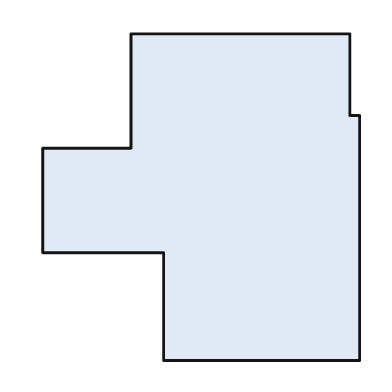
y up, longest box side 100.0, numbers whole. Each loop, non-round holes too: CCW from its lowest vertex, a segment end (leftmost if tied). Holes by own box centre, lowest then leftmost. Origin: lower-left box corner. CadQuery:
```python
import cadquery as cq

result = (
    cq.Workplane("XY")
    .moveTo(37.0, 0.0)
    .lineTo(97.0, 0.0)
    .lineTo(97.0, 75.0)
    .lineTo(94.0, 75.0)
    .lineTo(94.0, 100.0)
    .lineTo(27.0, 100.0)
    .lineTo(27.0, 65.0)
    .lineTo(0.0, 65.0)
    .lineTo(0.0, 33.0)
    .lineTo(37.0, 33.0)
    .close()
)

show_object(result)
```